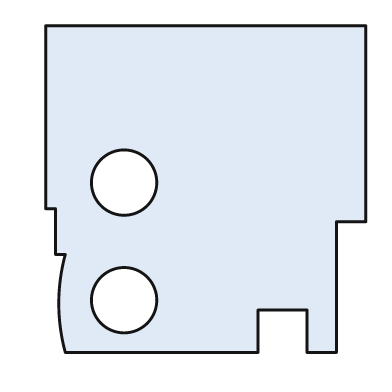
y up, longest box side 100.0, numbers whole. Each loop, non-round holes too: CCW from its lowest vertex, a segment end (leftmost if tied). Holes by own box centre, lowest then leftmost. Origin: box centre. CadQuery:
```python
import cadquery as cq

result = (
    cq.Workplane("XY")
    .moveTo(-43.0, -50.0)
    .lineTo(16.0, -50.0)
    .lineTo(16.0, -37.0)
    .lineTo(31.0, -37.0)
    .lineTo(31.0, -50.0)
    .lineTo(40.0, -50.0)
    .lineTo(40.0, -10.0)
    .lineTo(49.0, -10.0)
    .lineTo(49.0, 50.0)
    .lineTo(-49.0, 50.0)
    .lineTo(-49.0, -6.0)
    .lineTo(-46.0, -6.0)
    .lineTo(-46.0, -20.0)
    .lineTo(-43.0, -20.0)
    .threePointArc((-45.0, -35.0), (-43.0, -50.0))
    .close()
    .moveTo(-25.0, -34.0)
    .circle(10.0)
    .moveTo(-25.0, 2.0)
    .circle(10.0)
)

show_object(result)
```